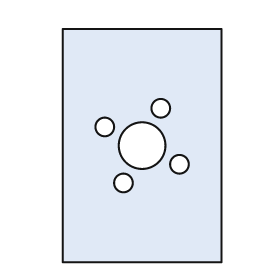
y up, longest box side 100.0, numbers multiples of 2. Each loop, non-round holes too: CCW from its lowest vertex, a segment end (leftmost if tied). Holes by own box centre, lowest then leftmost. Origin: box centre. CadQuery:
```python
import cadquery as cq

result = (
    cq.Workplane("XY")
    .moveTo(-34.0, -50.0)
    .lineTo(34.0, -50.0)
    .lineTo(34.0, 50.0)
    .lineTo(-34.0, 50.0)
    .close()
    .moveTo(-8.0, -16.0)
    .circle(4.0)
    .moveTo(16.0, -8.0)
    .circle(4.0)
    .moveTo(0.0, 0.0)
    .circle(10.0)
    .moveTo(-16.0, 8.0)
    .circle(4.0)
    .moveTo(8.0, 16.0)
    .circle(4.0)
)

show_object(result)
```